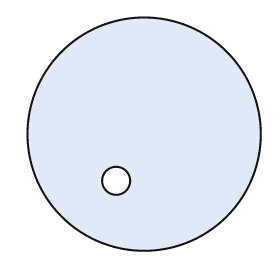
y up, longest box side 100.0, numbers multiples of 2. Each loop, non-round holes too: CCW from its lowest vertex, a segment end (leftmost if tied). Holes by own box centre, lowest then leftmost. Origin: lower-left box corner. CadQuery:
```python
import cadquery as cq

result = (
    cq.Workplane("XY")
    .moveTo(50.0, 50.0)
    .circle(50.0)
    .moveTo(38.0, 30.0)
    .circle(6.0)
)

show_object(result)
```